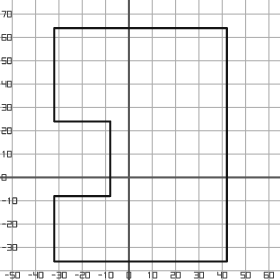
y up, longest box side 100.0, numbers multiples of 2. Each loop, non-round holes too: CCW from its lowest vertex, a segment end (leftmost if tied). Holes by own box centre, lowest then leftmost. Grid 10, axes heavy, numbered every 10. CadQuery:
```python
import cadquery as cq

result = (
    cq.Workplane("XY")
    .moveTo(-32.0, -36.0)
    .lineTo(42.0, -36.0)
    .lineTo(42.0, 64.0)
    .lineTo(-32.0, 64.0)
    .lineTo(-32.0, 24.0)
    .lineTo(-8.0, 24.0)
    .lineTo(-8.0, -8.0)
    .lineTo(-32.0, -8.0)
    .close()
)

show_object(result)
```